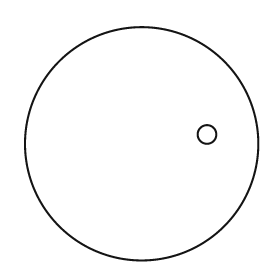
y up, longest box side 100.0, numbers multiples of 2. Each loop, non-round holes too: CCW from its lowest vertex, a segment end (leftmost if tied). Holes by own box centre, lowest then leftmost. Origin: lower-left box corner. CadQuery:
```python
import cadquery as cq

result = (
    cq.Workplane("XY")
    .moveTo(50.0, 50.0)
    .circle(50.0)
    .moveTo(78.0, 54.0)
    .circle(4.0)
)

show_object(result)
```